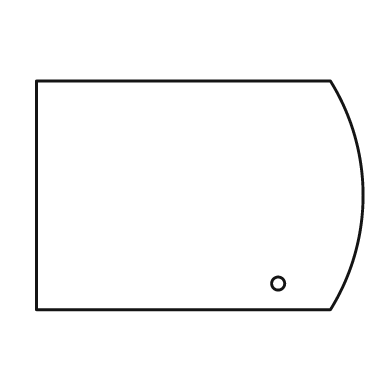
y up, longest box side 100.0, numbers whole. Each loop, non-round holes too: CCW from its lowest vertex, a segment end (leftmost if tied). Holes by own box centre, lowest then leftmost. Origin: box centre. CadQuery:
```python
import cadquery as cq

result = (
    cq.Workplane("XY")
    .moveTo(-50.0, -35.0)
    .lineTo(40.0, -35.0)
    .threePointArc((50.0, 0.0), (40.0, 35.0))
    .lineTo(-50.0, 35.0)
    .close()
    .moveTo(24.0, -27.0)
    .circle(2.0)
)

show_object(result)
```